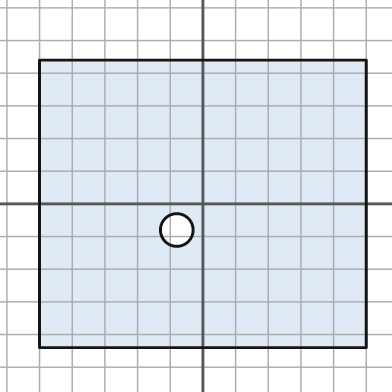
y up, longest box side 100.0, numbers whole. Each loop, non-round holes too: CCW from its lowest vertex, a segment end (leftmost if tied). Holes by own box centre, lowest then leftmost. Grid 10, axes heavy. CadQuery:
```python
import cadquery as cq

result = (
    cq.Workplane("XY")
    .moveTo(-50.0, -44.0)
    .lineTo(50.0, -44.0)
    .lineTo(50.0, 44.0)
    .lineTo(-50.0, 44.0)
    .close()
    .moveTo(-8.0, -8.0)
    .circle(5.0)
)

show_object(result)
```